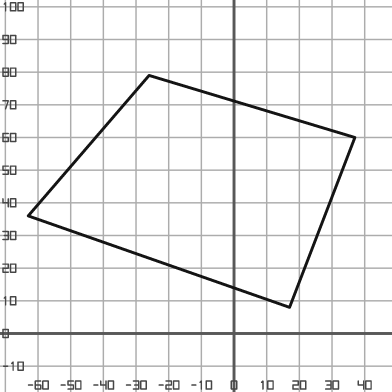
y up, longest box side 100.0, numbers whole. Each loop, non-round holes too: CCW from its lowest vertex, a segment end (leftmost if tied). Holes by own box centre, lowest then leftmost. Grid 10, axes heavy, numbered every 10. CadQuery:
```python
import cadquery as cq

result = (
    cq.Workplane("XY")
    .moveTo(17.0, 8.0)
    .lineTo(37.0, 60.0)
    .lineTo(-26.0, 79.0)
    .lineTo(-63.0, 36.0)
    .close()
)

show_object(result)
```